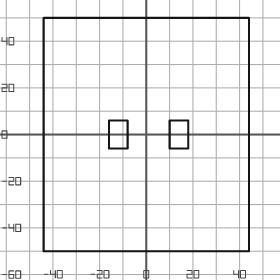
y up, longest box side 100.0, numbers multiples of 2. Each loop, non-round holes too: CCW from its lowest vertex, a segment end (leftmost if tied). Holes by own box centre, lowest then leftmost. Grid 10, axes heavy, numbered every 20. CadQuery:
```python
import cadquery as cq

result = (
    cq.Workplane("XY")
    .moveTo(-44.0, -50.0)
    .lineTo(44.0, -50.0)
    .lineTo(44.0, 50.0)
    .lineTo(-44.0, 50.0)
    .close()
    .moveTo(-16.0, -6.0)
    .lineTo(-8.0, -6.0)
    .lineTo(-8.0, 6.0)
    .lineTo(-16.0, 6.0)
    .close()
    .moveTo(10.0, -6.0)
    .lineTo(18.0, -6.0)
    .lineTo(18.0, 6.0)
    .lineTo(10.0, 6.0)
    .close()
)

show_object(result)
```